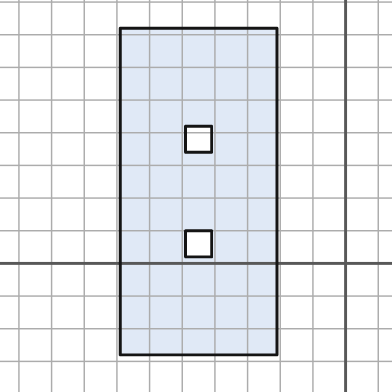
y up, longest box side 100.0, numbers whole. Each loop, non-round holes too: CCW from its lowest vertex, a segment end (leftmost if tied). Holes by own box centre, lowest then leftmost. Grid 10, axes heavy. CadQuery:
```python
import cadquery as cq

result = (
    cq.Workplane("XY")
    .moveTo(-69.0, -28.0)
    .lineTo(-21.0, -28.0)
    .lineTo(-21.0, 72.0)
    .lineTo(-69.0, 72.0)
    .close()
    .moveTo(-49.0, 2.0)
    .lineTo(-41.0, 2.0)
    .lineTo(-41.0, 10.0)
    .lineTo(-49.0, 10.0)
    .close()
    .moveTo(-49.0, 34.0)
    .lineTo(-41.0, 34.0)
    .lineTo(-41.0, 42.0)
    .lineTo(-49.0, 42.0)
    .close()
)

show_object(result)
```